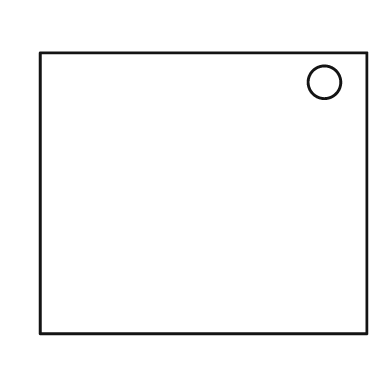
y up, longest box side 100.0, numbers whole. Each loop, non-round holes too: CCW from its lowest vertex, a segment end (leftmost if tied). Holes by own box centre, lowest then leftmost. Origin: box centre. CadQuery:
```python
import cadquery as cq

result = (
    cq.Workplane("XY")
    .moveTo(-50.0, -43.0)
    .lineTo(50.0, -43.0)
    .lineTo(50.0, 43.0)
    .lineTo(-50.0, 43.0)
    .close()
    .moveTo(37.0, 34.0)
    .circle(5.0)
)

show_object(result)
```